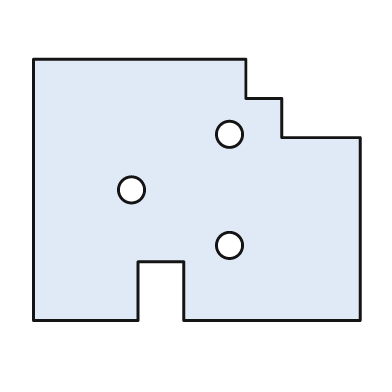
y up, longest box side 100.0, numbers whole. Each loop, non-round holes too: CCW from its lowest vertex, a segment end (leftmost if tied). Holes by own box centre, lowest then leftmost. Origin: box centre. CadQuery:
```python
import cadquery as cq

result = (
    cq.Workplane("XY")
    .moveTo(-50.0, -40.0)
    .lineTo(-18.0, -40.0)
    .lineTo(-18.0, -22.0)
    .lineTo(-4.0, -22.0)
    .lineTo(-4.0, -40.0)
    .lineTo(50.0, -40.0)
    .lineTo(50.0, 16.0)
    .lineTo(26.0, 16.0)
    .lineTo(26.0, 28.0)
    .lineTo(15.0, 28.0)
    .lineTo(15.0, 40.0)
    .lineTo(-50.0, 40.0)
    .close()
    .moveTo(10.0, -17.0)
    .circle(4.0)
    .moveTo(-20.0, 0.0)
    .circle(4.0)
    .moveTo(10.0, 17.0)
    .circle(4.0)
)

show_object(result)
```